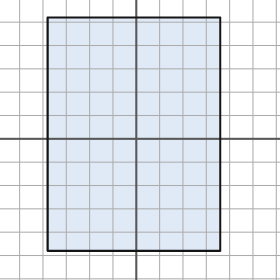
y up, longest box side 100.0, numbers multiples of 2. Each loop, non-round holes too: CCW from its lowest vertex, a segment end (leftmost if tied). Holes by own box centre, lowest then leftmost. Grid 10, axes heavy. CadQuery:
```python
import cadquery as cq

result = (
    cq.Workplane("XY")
    .moveTo(-38.0, -48.0)
    .lineTo(36.0, -48.0)
    .lineTo(36.0, 52.0)
    .lineTo(-38.0, 52.0)
    .close()
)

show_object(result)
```